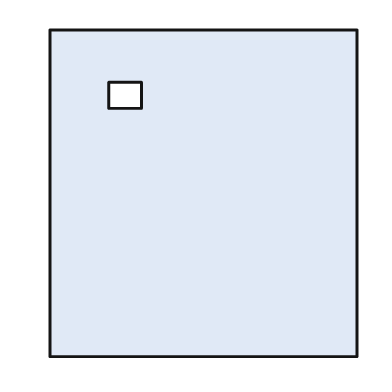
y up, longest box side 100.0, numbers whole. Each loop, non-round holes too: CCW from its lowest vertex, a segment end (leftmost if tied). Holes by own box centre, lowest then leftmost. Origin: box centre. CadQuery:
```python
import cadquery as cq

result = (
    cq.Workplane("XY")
    .moveTo(-47.0, -50.0)
    .lineTo(47.0, -50.0)
    .lineTo(47.0, 50.0)
    .lineTo(-47.0, 50.0)
    .close()
    .moveTo(-29.0, 26.0)
    .lineTo(-19.0, 26.0)
    .lineTo(-19.0, 34.0)
    .lineTo(-29.0, 34.0)
    .close()
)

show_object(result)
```